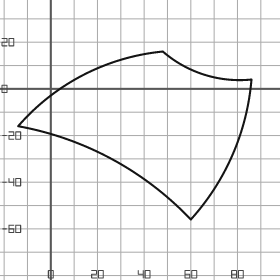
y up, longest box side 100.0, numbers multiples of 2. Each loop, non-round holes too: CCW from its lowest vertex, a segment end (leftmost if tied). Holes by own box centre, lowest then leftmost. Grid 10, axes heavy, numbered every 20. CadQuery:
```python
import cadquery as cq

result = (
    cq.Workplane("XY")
    .moveTo(60.0, -56.0)
    .threePointArc((78.0, -28.0), (86.0, 4.0))
    .threePointArc((66.0, 6.0), (48.0, 16.0))
    .threePointArc((14.0, 6.0), (-14.0, -16.0))
    .threePointArc((26.0, -30.0), (60.0, -56.0))
    .close()
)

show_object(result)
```